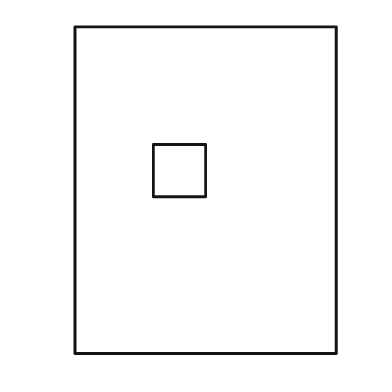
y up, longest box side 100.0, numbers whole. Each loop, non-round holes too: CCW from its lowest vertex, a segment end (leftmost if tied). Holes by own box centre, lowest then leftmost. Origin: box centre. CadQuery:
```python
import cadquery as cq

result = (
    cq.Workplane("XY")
    .moveTo(-40.0, -50.0)
    .lineTo(40.0, -50.0)
    .lineTo(40.0, 50.0)
    .lineTo(-40.0, 50.0)
    .close()
    .moveTo(-16.0, -2.0)
    .lineTo(0.0, -2.0)
    .lineTo(0.0, 14.0)
    .lineTo(-16.0, 14.0)
    .close()
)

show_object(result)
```